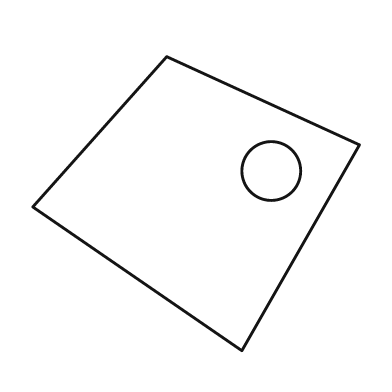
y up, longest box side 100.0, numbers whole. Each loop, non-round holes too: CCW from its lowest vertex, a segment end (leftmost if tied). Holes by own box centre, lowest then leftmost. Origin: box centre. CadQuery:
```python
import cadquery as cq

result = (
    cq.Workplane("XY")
    .moveTo(14.0, -45.0)
    .lineTo(50.0, 18.0)
    .lineTo(-9.0, 45.0)
    .lineTo(-50.0, -1.0)
    .close()
    .moveTo(23.0, 10.0)
    .circle(9.0)
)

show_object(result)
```